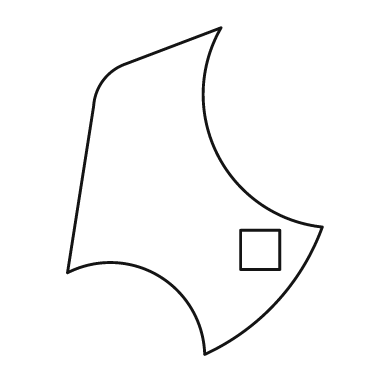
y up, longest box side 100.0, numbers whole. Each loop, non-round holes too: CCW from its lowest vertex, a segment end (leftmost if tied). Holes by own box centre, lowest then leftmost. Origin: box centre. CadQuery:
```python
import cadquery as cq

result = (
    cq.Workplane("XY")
    .moveTo(3.0, -50.0)
    .threePointArc((25.0, -34.0), (39.0, -11.0))
    .threePointArc((7.0, 11.0), (8.0, 50.0))
    .lineTo(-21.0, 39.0)
    .threePointArc((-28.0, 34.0), (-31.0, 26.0))
    .lineTo(-39.0, -25.0)
    .threePointArc((-11.0, -26.0), (3.0, -50.0))
    .close()
    .moveTo(14.0, -24.0)
    .lineTo(26.0, -24.0)
    .lineTo(26.0, -12.0)
    .lineTo(14.0, -12.0)
    .close()
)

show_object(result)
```